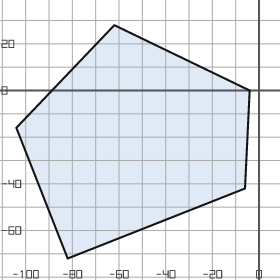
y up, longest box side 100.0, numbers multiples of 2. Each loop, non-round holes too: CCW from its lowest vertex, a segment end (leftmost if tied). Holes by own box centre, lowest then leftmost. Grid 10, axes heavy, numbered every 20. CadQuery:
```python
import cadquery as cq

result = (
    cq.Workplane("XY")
    .moveTo(-82.0, -72.0)
    .lineTo(-6.0, -42.0)
    .lineTo(-4.0, 0.0)
    .lineTo(-62.0, 28.0)
    .lineTo(-104.0, -16.0)
    .close()
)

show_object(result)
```